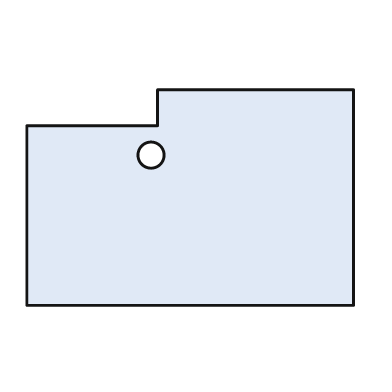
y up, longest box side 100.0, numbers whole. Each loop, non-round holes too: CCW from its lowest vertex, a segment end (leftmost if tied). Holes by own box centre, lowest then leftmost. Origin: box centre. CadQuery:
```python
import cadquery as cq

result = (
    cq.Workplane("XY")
    .moveTo(-50.0, -33.0)
    .lineTo(50.0, -33.0)
    .lineTo(50.0, 33.0)
    .lineTo(-10.0, 33.0)
    .lineTo(-10.0, 22.0)
    .lineTo(-50.0, 22.0)
    .close()
    .moveTo(-12.0, 13.0)
    .circle(4.0)
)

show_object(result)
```